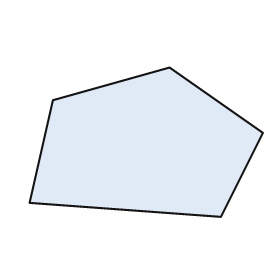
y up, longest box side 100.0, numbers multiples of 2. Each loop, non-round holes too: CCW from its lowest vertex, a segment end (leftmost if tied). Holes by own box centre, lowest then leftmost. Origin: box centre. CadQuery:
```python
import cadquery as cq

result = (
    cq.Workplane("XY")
    .moveTo(32.0, -32.0)
    .lineTo(50.0, 4.0)
    .lineTo(10.0, 32.0)
    .lineTo(-40.0, 18.0)
    .lineTo(-50.0, -26.0)
    .close()
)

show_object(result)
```